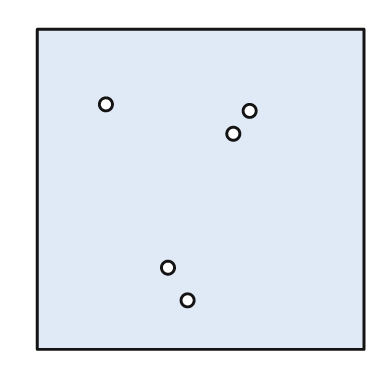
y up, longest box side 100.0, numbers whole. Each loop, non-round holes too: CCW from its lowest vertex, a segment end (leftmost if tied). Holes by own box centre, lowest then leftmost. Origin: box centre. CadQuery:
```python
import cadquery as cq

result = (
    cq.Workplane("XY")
    .moveTo(-50.0, -49.0)
    .lineTo(50.0, -49.0)
    .lineTo(50.0, 49.0)
    .lineTo(-50.0, 49.0)
    .close()
    .moveTo(-4.0, -34.0)
    .circle(2.0)
    .moveTo(-10.0, -24.0)
    .circle(2.0)
    .moveTo(10.0, 17.0)
    .circle(2.0)
    .moveTo(15.0, 24.0)
    .circle(2.0)
    .moveTo(-29.0, 26.0)
    .circle(2.0)
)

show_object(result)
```